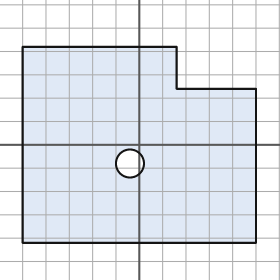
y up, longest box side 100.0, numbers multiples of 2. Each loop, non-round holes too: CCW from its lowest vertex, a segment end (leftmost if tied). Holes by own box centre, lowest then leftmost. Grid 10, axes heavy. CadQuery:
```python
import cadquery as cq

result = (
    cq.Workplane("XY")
    .moveTo(-50.0, -42.0)
    .lineTo(50.0, -42.0)
    .lineTo(50.0, 24.0)
    .lineTo(16.0, 24.0)
    .lineTo(16.0, 42.0)
    .lineTo(-50.0, 42.0)
    .close()
    .moveTo(-4.0, -8.0)
    .circle(6.0)
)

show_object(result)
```